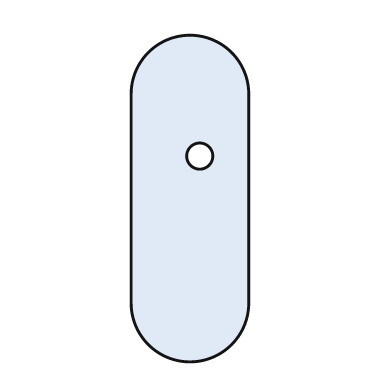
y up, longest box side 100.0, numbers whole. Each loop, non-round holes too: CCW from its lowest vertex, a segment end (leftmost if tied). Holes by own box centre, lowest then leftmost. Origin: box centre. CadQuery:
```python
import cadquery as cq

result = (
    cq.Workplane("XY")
    .moveTo(-18.0, -32.0)
    .threePointArc((0.0, -50.0), (18.0, -32.0))
    .lineTo(18.0, 32.0)
    .threePointArc((0.0, 50.0), (-18.0, 32.0))
    .close()
    .moveTo(3.0, 13.0)
    .circle(4.0)
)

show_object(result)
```